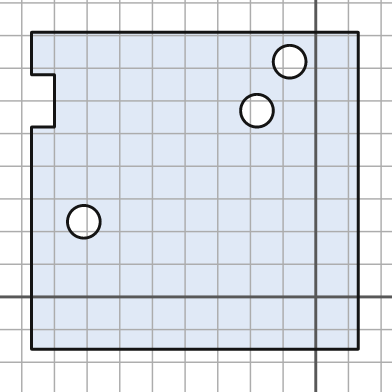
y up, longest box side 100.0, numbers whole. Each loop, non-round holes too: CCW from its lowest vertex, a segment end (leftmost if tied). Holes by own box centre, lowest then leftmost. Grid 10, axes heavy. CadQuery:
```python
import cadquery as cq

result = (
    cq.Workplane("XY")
    .moveTo(-87.0, -16.0)
    .lineTo(13.0, -16.0)
    .lineTo(13.0, 81.0)
    .lineTo(-87.0, 81.0)
    .lineTo(-87.0, 68.0)
    .lineTo(-80.0, 68.0)
    .lineTo(-80.0, 52.0)
    .lineTo(-87.0, 52.0)
    .close()
    .moveTo(-71.0, 23.0)
    .circle(5.0)
    .moveTo(-18.0, 57.0)
    .circle(5.0)
    .moveTo(-8.0, 72.0)
    .circle(5.0)
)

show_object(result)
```